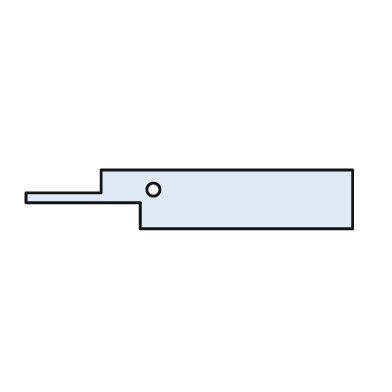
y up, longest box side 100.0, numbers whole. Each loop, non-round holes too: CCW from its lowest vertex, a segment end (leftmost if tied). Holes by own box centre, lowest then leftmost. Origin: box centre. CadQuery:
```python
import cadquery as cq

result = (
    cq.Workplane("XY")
    .moveTo(-15.0, -9.0)
    .lineTo(50.0, -9.0)
    .lineTo(50.0, 9.0)
    .lineTo(-27.0, 9.0)
    .lineTo(-27.0, 2.0)
    .lineTo(-50.0, 2.0)
    .lineTo(-50.0, -1.0)
    .lineTo(-15.0, -1.0)
    .close()
    .moveTo(-11.0, 3.0)
    .circle(2.0)
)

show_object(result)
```